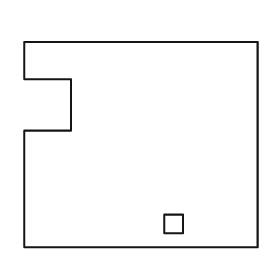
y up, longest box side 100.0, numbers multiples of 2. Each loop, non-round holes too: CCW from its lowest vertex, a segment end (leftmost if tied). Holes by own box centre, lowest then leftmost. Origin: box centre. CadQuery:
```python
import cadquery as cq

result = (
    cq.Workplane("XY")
    .moveTo(-50.0, -44.0)
    .lineTo(50.0, -44.0)
    .lineTo(50.0, 44.0)
    .lineTo(-50.0, 44.0)
    .lineTo(-50.0, 28.0)
    .lineTo(-30.0, 28.0)
    .lineTo(-30.0, 6.0)
    .lineTo(-50.0, 6.0)
    .close()
    .moveTo(10.0, -38.0)
    .lineTo(18.0, -38.0)
    .lineTo(18.0, -30.0)
    .lineTo(10.0, -30.0)
    .close()
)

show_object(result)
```